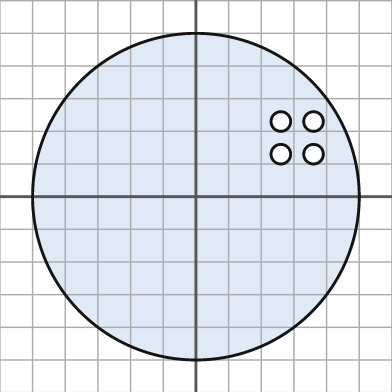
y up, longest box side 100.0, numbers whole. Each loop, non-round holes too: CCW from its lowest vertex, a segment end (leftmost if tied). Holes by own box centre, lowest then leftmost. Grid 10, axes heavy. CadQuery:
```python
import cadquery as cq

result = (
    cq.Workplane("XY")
    .moveTo(0.0, 0.0)
    .circle(50.0)
    .moveTo(26.0, 13.0)
    .circle(3.0)
    .moveTo(36.0, 13.0)
    .circle(3.0)
    .moveTo(26.0, 23.0)
    .circle(3.0)
    .moveTo(36.0, 23.0)
    .circle(3.0)
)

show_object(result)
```